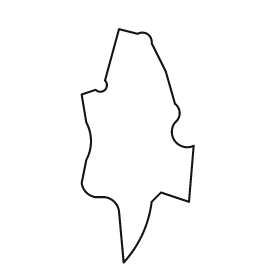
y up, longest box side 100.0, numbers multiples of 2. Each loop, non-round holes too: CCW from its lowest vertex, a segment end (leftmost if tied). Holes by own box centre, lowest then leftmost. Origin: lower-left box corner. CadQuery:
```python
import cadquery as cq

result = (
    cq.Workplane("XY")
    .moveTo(18.0, 0.0)
    .threePointArc((26.0, 12.0), (30.0, 26.0))
    .lineTo(34.0, 30.0)
    .lineTo(46.0, 26.0)
    .lineTo(48.0, 50.0)
    .threePointArc((40.0, 52.0), (40.0, 60.0))
    .threePointArc((42.0, 64.0), (40.0, 68.0))
    .lineTo(36.0, 82.0)
    .lineTo(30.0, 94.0)
    .threePointArc((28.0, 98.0), (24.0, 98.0))
    .lineTo(16.0, 100.0)
    .lineTo(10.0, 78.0)
    .threePointArc((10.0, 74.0), (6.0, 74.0))
    .lineTo(0.0, 72.0)
    .lineTo(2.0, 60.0)
    .threePointArc((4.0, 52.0), (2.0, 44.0))
    .lineTo(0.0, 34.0)
    .threePointArc((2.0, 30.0), (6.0, 28.0))
    .lineTo(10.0, 28.0)
    .threePointArc((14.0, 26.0), (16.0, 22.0))
    .close()
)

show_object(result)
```